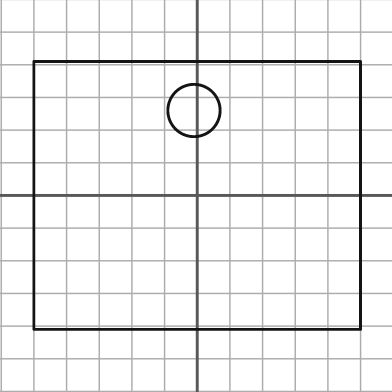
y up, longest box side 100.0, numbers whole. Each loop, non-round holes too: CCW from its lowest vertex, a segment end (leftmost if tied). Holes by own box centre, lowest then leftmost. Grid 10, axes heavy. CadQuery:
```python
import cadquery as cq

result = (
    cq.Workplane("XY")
    .moveTo(-50.0, -41.0)
    .lineTo(50.0, -41.0)
    .lineTo(50.0, 41.0)
    .lineTo(-50.0, 41.0)
    .close()
    .moveTo(-1.0, 26.0)
    .circle(8.0)
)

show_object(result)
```